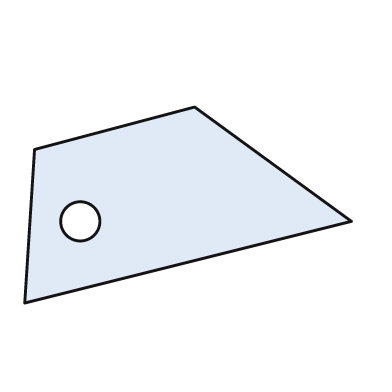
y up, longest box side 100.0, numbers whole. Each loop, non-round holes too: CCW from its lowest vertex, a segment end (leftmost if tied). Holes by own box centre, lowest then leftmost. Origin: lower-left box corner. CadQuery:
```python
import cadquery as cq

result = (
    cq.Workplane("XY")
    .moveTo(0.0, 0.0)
    .lineTo(100.0, 25.0)
    .lineTo(52.0, 60.0)
    .lineTo(3.0, 47.0)
    .close()
    .moveTo(17.0, 25.0)
    .circle(6.0)
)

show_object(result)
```